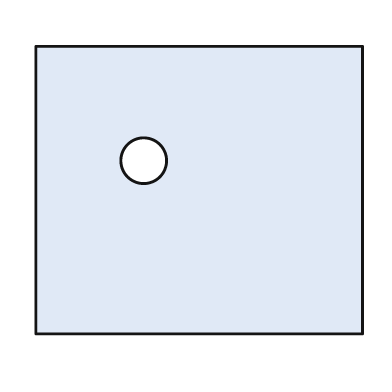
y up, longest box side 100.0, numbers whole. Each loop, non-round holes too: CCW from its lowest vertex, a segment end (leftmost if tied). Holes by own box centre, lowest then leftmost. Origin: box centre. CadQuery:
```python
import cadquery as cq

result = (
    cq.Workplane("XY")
    .moveTo(-50.0, -44.0)
    .lineTo(50.0, -44.0)
    .lineTo(50.0, 44.0)
    .lineTo(-50.0, 44.0)
    .close()
    .moveTo(-17.0, 9.0)
    .circle(7.0)
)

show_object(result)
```